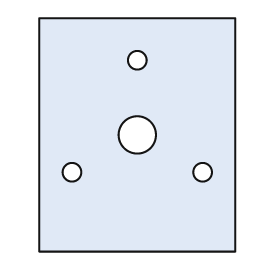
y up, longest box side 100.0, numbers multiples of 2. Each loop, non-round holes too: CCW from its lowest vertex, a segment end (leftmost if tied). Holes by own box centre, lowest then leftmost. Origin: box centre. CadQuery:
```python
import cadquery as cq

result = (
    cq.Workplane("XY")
    .moveTo(-42.0, -50.0)
    .lineTo(42.0, -50.0)
    .lineTo(42.0, 50.0)
    .lineTo(-42.0, 50.0)
    .close()
    .moveTo(-28.0, -16.0)
    .circle(4.0)
    .moveTo(28.0, -16.0)
    .circle(4.0)
    .moveTo(0.0, 0.0)
    .circle(8.0)
    .moveTo(0.0, 32.0)
    .circle(4.0)
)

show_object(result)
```